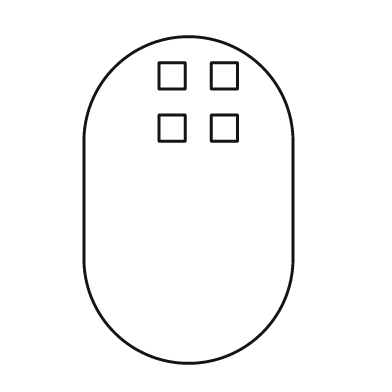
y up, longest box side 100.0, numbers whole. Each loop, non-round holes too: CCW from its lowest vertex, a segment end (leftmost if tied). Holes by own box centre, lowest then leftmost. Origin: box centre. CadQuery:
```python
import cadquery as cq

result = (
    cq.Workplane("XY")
    .moveTo(-32.0, -18.0)
    .threePointArc((0.0, -50.0), (32.0, -18.0))
    .lineTo(32.0, 18.0)
    .threePointArc((0.0, 50.0), (-32.0, 18.0))
    .close()
    .moveTo(-9.0, 18.0)
    .lineTo(-1.0, 18.0)
    .lineTo(-1.0, 26.0)
    .lineTo(-9.0, 26.0)
    .close()
    .moveTo(7.0, 18.0)
    .lineTo(15.0, 18.0)
    .lineTo(15.0, 26.0)
    .lineTo(7.0, 26.0)
    .close()
    .moveTo(-9.0, 34.0)
    .lineTo(-1.0, 34.0)
    .lineTo(-1.0, 42.0)
    .lineTo(-9.0, 42.0)
    .close()
    .moveTo(7.0, 34.0)
    .lineTo(15.0, 34.0)
    .lineTo(15.0, 42.0)
    .lineTo(7.0, 42.0)
    .close()
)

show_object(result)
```